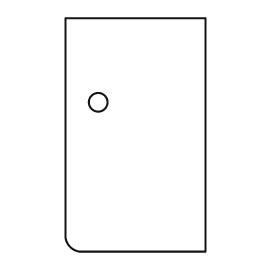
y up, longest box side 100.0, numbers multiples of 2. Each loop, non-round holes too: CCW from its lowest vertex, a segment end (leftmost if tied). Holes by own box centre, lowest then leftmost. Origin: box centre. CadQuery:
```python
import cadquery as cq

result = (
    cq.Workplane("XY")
    .moveTo(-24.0, -50.0)
    .lineTo(30.0, -50.0)
    .lineTo(30.0, 50.0)
    .lineTo(-30.0, 50.0)
    .lineTo(-30.0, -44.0)
    .threePointArc((-28.0, -48.0), (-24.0, -50.0))
    .close()
    .moveTo(-16.0, 14.0)
    .circle(4.0)
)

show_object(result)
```